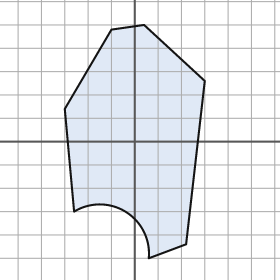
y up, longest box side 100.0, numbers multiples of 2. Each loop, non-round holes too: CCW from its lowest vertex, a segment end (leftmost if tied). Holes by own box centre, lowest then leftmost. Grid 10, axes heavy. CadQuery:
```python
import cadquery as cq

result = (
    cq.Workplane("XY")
    .moveTo(6.0, -50.0)
    .lineTo(22.0, -44.0)
    .lineTo(30.0, 26.0)
    .lineTo(4.0, 50.0)
    .lineTo(-10.0, 48.0)
    .lineTo(-30.0, 14.0)
    .lineTo(-26.0, -30.0)
    .threePointArc((-4.0, -30.0), (6.0, -50.0))
    .close()
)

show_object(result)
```